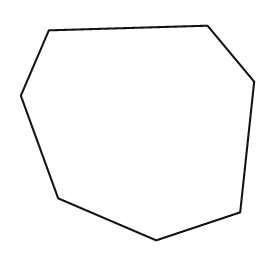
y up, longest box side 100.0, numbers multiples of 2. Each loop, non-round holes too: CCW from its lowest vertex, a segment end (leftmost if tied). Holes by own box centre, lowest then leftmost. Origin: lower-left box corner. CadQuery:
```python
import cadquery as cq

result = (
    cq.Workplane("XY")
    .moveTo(58.0, 0.0)
    .lineTo(94.0, 12.0)
    .lineTo(100.0, 68.0)
    .lineTo(80.0, 92.0)
    .lineTo(12.0, 90.0)
    .lineTo(0.0, 62.0)
    .lineTo(16.0, 18.0)
    .close()
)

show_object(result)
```